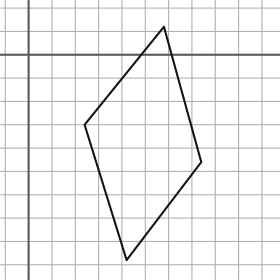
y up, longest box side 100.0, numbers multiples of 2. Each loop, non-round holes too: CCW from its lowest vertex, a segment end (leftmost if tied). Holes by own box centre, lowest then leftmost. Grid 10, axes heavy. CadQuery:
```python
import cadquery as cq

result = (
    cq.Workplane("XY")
    .moveTo(42.0, -88.0)
    .lineTo(74.0, -46.0)
    .lineTo(58.0, 12.0)
    .lineTo(24.0, -30.0)
    .close()
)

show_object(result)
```